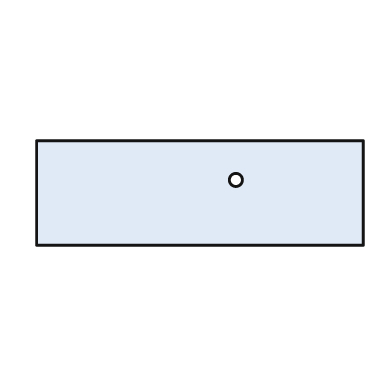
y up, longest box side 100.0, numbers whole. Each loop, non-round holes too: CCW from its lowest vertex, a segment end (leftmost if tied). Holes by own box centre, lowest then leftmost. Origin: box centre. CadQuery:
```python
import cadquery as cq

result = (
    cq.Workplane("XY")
    .moveTo(-50.0, -16.0)
    .lineTo(50.0, -16.0)
    .lineTo(50.0, 16.0)
    .lineTo(-50.0, 16.0)
    .close()
    .moveTo(11.0, 4.0)
    .circle(2.0)
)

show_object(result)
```